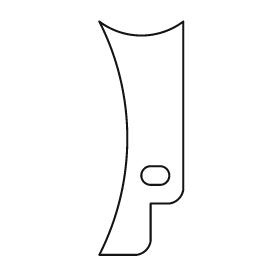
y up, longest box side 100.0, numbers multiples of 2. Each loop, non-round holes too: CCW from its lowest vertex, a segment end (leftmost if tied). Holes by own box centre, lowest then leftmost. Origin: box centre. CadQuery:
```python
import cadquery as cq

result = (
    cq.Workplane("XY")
    .moveTo(-18.0, -50.0)
    .lineTo(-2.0, -50.0)
    .threePointArc((2.0, -48.0), (4.0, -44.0))
    .lineTo(4.0, -28.0)
    .lineTo(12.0, -28.0)
    .threePointArc((16.0, -26.0), (18.0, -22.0))
    .lineTo(18.0, 50.0)
    .threePointArc((0.0, 44.0), (-18.0, 50.0))
    .threePointArc((-6.0, 0.0), (-18.0, -50.0))
    .close()
    .moveTo(4.0, -20.0)
    .lineTo(8.0, -20.0)
    .threePointArc((12.0, -16.0), (8.0, -12.0))
    .lineTo(4.0, -12.0)
    .threePointArc((0.0, -16.0), (4.0, -20.0))
    .close()
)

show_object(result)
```